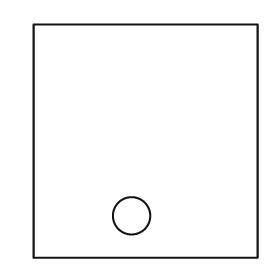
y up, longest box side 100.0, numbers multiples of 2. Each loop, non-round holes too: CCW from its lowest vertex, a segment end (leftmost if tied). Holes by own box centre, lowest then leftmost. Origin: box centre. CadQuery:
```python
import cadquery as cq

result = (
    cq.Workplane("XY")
    .moveTo(-48.0, -50.0)
    .lineTo(48.0, -50.0)
    .lineTo(48.0, 50.0)
    .lineTo(-48.0, 50.0)
    .close()
    .moveTo(-6.0, -32.0)
    .circle(8.0)
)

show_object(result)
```